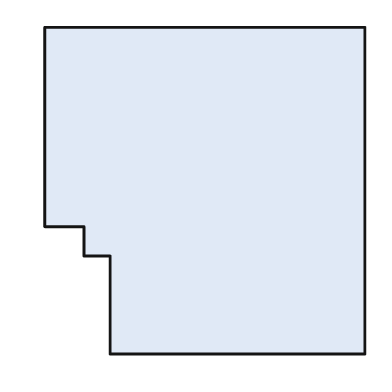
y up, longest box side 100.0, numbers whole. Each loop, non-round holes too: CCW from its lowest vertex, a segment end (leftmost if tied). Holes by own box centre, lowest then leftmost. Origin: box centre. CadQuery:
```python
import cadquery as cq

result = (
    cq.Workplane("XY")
    .moveTo(-29.0, -50.0)
    .lineTo(49.0, -50.0)
    .lineTo(49.0, 50.0)
    .lineTo(-49.0, 50.0)
    .lineTo(-49.0, -11.0)
    .lineTo(-37.0, -11.0)
    .lineTo(-37.0, -20.0)
    .lineTo(-29.0, -20.0)
    .close()
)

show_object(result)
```